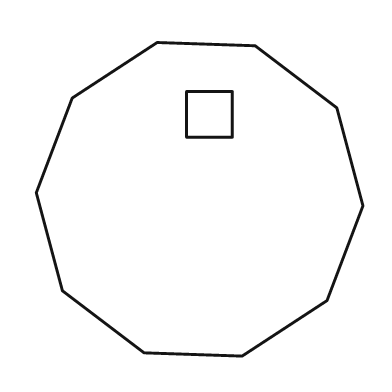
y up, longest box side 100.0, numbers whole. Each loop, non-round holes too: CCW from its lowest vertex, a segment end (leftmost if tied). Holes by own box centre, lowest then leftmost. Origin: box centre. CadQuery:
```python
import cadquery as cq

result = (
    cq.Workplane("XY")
    .moveTo(13.0, -48.0)
    .lineTo(39.0, -31.0)
    .lineTo(50.0, -2.0)
    .lineTo(42.0, 28.0)
    .lineTo(17.0, 47.0)
    .lineTo(-13.0, 48.0)
    .lineTo(-39.0, 31.0)
    .lineTo(-50.0, 2.0)
    .lineTo(-42.0, -28.0)
    .lineTo(-17.0, -47.0)
    .close()
    .moveTo(-4.0, 19.0)
    .lineTo(10.0, 19.0)
    .lineTo(10.0, 33.0)
    .lineTo(-4.0, 33.0)
    .close()
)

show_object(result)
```